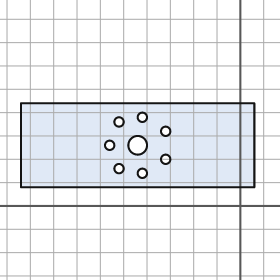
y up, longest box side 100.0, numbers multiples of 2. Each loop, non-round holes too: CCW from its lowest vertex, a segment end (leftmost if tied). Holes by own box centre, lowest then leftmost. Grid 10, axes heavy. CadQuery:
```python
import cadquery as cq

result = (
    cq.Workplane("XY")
    .moveTo(-94.0, 8.0)
    .lineTo(6.0, 8.0)
    .lineTo(6.0, 44.0)
    .lineTo(-94.0, 44.0)
    .close()
    .moveTo(-42.0, 14.0)
    .circle(2.0)
    .moveTo(-52.0, 16.0)
    .circle(2.0)
    .moveTo(-32.0, 20.0)
    .circle(2.0)
    .moveTo(-56.0, 26.0)
    .circle(2.0)
    .moveTo(-44.0, 26.0)
    .circle(4.0)
    .moveTo(-32.0, 32.0)
    .circle(2.0)
    .moveTo(-52.0, 36.0)
    .circle(2.0)
    .moveTo(-42.0, 38.0)
    .circle(2.0)
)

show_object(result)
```